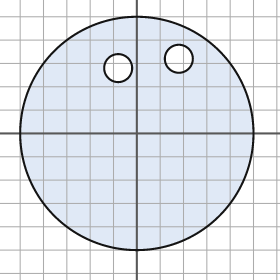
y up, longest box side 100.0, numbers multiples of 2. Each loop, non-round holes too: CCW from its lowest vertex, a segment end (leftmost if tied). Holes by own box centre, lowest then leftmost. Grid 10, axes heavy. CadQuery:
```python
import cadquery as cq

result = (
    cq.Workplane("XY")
    .moveTo(0.0, 0.0)
    .circle(50.0)
    .moveTo(-8.0, 28.0)
    .circle(6.0)
    .moveTo(18.0, 32.0)
    .circle(6.0)
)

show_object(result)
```